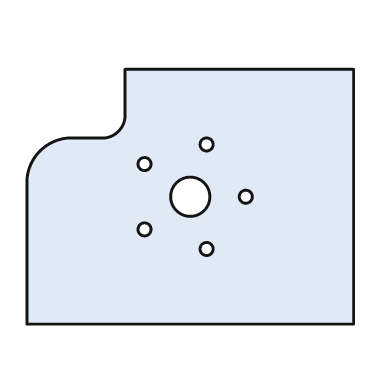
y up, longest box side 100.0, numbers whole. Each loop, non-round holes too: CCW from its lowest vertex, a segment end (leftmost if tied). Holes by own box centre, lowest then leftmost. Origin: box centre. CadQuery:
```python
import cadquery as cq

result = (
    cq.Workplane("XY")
    .moveTo(-50.0, -39.0)
    .lineTo(50.0, -39.0)
    .lineTo(50.0, 39.0)
    .lineTo(-20.0, 39.0)
    .lineTo(-20.0, 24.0)
    .threePointArc((-22.0, 20.0), (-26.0, 18.0))
    .lineTo(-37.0, 18.0)
    .threePointArc((-46.0, 14.0), (-50.0, 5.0))
    .close()
    .moveTo(5.0, -16.0)
    .circle(2.0)
    .moveTo(-14.0, -10.0)
    .circle(2.0)
    .moveTo(0.0, 0.0)
    .circle(6.0)
    .moveTo(17.0, 0.0)
    .circle(2.0)
    .moveTo(-14.0, 10.0)
    .circle(2.0)
    .moveTo(5.0, 16.0)
    .circle(2.0)
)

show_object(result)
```